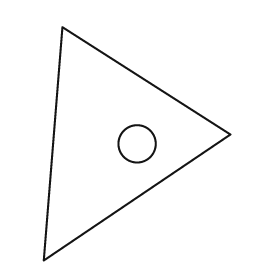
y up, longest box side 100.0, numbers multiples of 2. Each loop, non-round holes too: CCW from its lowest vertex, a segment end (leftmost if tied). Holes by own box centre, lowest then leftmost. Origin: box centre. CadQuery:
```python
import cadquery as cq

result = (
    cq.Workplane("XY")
    .moveTo(-40.0, -50.0)
    .lineTo(40.0, 4.0)
    .lineTo(-32.0, 50.0)
    .close()
    .moveTo(0.0, 0.0)
    .circle(8.0)
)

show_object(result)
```